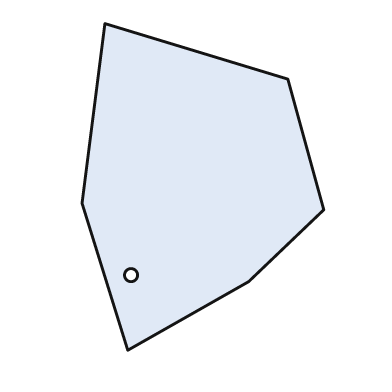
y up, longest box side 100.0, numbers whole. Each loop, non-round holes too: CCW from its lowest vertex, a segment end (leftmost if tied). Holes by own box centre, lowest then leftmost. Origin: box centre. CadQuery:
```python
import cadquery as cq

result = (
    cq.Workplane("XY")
    .moveTo(-23.0, -50.0)
    .lineTo(14.0, -29.0)
    .lineTo(37.0, -7.0)
    .lineTo(26.0, 33.0)
    .lineTo(-30.0, 50.0)
    .lineTo(-37.0, -5.0)
    .close()
    .moveTo(-22.0, -27.0)
    .circle(2.0)
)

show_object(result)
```